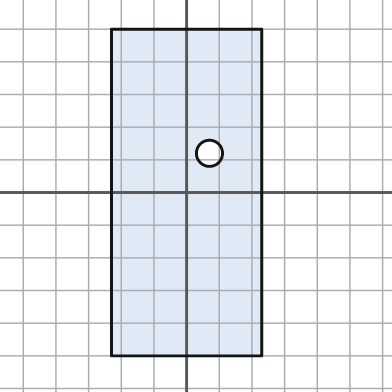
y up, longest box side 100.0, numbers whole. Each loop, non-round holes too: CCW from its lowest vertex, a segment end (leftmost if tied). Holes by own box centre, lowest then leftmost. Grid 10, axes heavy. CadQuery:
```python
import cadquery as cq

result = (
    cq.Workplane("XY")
    .moveTo(-23.0, -50.0)
    .lineTo(23.0, -50.0)
    .lineTo(23.0, 50.0)
    .lineTo(-23.0, 50.0)
    .close()
    .moveTo(7.0, 12.0)
    .circle(4.0)
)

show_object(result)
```